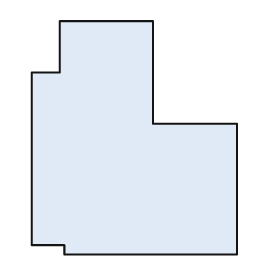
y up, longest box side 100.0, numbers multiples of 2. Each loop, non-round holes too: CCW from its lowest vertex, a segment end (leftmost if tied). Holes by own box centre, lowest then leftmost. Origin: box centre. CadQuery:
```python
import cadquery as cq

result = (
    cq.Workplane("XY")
    .moveTo(-30.0, -50.0)
    .lineTo(44.0, -50.0)
    .lineTo(44.0, 6.0)
    .lineTo(8.0, 6.0)
    .lineTo(8.0, 50.0)
    .lineTo(-32.0, 50.0)
    .lineTo(-32.0, 28.0)
    .lineTo(-44.0, 28.0)
    .lineTo(-44.0, -46.0)
    .lineTo(-30.0, -46.0)
    .close()
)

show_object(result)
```